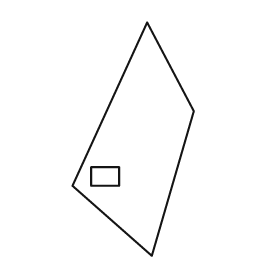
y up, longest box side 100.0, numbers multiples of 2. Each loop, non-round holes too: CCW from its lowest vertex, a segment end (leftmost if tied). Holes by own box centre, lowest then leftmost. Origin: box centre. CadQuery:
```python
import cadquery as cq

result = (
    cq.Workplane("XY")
    .moveTo(8.0, -50.0)
    .lineTo(26.0, 12.0)
    .lineTo(6.0, 50.0)
    .lineTo(-26.0, -20.0)
    .close()
    .moveTo(-18.0, -20.0)
    .lineTo(-6.0, -20.0)
    .lineTo(-6.0, -12.0)
    .lineTo(-18.0, -12.0)
    .close()
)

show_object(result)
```